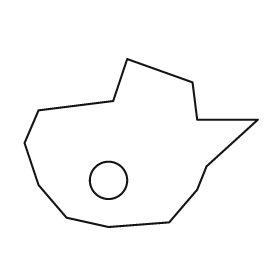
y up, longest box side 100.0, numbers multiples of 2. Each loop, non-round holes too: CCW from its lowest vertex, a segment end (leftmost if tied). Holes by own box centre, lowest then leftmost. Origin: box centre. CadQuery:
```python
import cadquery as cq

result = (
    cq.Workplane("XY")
    .moveTo(-14.0, -36.0)
    .lineTo(12.0, -34.0)
    .lineTo(24.0, -20.0)
    .lineTo(28.0, -10.0)
    .lineTo(50.0, 10.0)
    .lineTo(24.0, 10.0)
    .lineTo(22.0, 26.0)
    .lineTo(-6.0, 36.0)
    .lineTo(-12.0, 18.0)
    .lineTo(-44.0, 14.0)
    .lineTo(-50.0, 0.0)
    .lineTo(-44.0, -18.0)
    .lineTo(-32.0, -32.0)
    .close()
    .moveTo(-14.0, -16.0)
    .circle(8.0)
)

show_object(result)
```